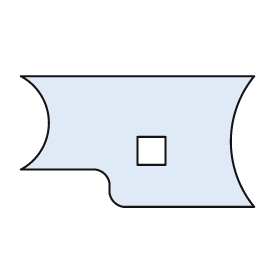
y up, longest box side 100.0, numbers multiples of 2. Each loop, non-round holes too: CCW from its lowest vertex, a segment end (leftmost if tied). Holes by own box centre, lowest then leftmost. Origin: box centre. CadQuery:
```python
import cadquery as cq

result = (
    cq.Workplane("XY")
    .moveTo(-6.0, -28.0)
    .lineTo(50.0, -28.0)
    .threePointArc((40.0, 0.0), (50.0, 28.0))
    .lineTo(-50.0, 28.0)
    .threePointArc((-38.0, 8.0), (-50.0, -12.0))
    .lineTo(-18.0, -12.0)
    .threePointArc((-14.0, -14.0), (-12.0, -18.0))
    .lineTo(-12.0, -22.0)
    .threePointArc((-10.0, -26.0), (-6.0, -28.0))
    .close()
    .moveTo(0.0, -10.0)
    .lineTo(12.0, -10.0)
    .lineTo(12.0, 2.0)
    .lineTo(0.0, 2.0)
    .close()
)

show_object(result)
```